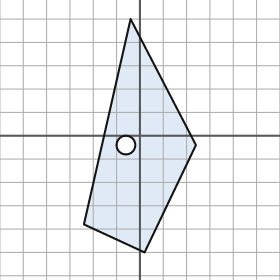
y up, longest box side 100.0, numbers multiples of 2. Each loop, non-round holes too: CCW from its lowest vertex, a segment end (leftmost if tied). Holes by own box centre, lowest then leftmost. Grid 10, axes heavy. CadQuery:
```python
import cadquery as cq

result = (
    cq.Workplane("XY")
    .moveTo(2.0, -50.0)
    .lineTo(24.0, -4.0)
    .lineTo(-4.0, 50.0)
    .lineTo(-24.0, -38.0)
    .close()
    .moveTo(-6.0, -4.0)
    .circle(4.0)
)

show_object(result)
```